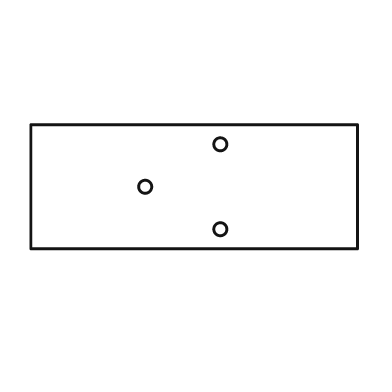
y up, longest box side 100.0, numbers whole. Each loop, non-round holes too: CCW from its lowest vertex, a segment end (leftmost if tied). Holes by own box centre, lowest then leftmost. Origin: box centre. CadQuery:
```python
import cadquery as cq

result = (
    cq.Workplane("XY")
    .moveTo(-50.0, -19.0)
    .lineTo(50.0, -19.0)
    .lineTo(50.0, 19.0)
    .lineTo(-50.0, 19.0)
    .close()
    .moveTo(8.0, -13.0)
    .circle(2.0)
    .moveTo(-15.0, 0.0)
    .circle(2.0)
    .moveTo(8.0, 13.0)
    .circle(2.0)
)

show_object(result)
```